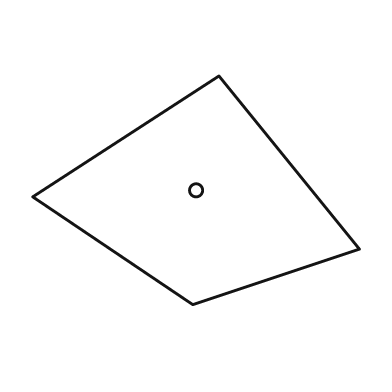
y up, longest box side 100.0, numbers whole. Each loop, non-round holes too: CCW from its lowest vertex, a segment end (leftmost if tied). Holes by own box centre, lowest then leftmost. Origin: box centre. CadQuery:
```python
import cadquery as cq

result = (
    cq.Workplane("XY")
    .moveTo(-1.0, -35.0)
    .lineTo(50.0, -18.0)
    .lineTo(7.0, 35.0)
    .lineTo(-50.0, -2.0)
    .close()
    .moveTo(0.0, 0.0)
    .circle(2.0)
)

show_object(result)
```